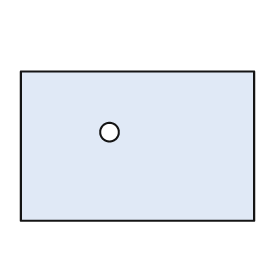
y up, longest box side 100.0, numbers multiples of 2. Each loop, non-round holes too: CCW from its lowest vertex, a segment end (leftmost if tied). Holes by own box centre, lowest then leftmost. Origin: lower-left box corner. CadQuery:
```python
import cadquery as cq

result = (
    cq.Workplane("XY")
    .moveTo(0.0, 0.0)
    .lineTo(100.0, 0.0)
    .lineTo(100.0, 64.0)
    .lineTo(0.0, 64.0)
    .close()
    .moveTo(38.0, 38.0)
    .circle(4.0)
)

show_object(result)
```